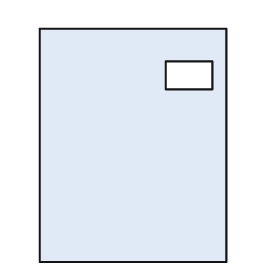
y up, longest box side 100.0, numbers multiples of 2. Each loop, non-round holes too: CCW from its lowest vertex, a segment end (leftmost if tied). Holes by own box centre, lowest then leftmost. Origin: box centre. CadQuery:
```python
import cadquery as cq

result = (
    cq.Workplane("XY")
    .moveTo(-40.0, -50.0)
    .lineTo(40.0, -50.0)
    .lineTo(40.0, 50.0)
    .lineTo(-40.0, 50.0)
    .close()
    .moveTo(14.0, 24.0)
    .lineTo(34.0, 24.0)
    .lineTo(34.0, 36.0)
    .lineTo(14.0, 36.0)
    .close()
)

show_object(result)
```